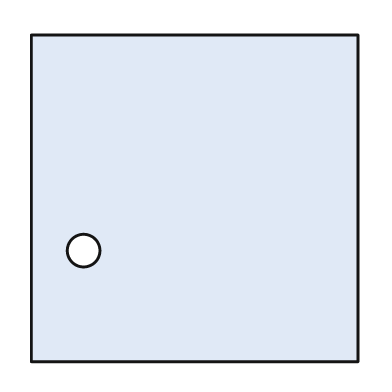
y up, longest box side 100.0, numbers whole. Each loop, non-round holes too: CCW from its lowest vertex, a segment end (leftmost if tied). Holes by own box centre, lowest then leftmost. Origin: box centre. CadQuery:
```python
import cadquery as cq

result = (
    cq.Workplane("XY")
    .moveTo(-50.0, -50.0)
    .lineTo(50.0, -50.0)
    .lineTo(50.0, 50.0)
    .lineTo(-50.0, 50.0)
    .close()
    .moveTo(-34.0, -16.0)
    .circle(5.0)
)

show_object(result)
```